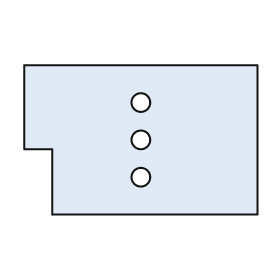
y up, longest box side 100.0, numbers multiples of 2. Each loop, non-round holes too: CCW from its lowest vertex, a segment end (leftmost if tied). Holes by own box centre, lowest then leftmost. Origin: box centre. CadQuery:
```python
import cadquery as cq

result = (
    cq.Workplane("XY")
    .moveTo(-38.0, -32.0)
    .lineTo(50.0, -32.0)
    .lineTo(50.0, 32.0)
    .lineTo(-50.0, 32.0)
    .lineTo(-50.0, -4.0)
    .lineTo(-38.0, -4.0)
    .close()
    .moveTo(0.0, -16.0)
    .circle(4.0)
    .moveTo(0.0, 0.0)
    .circle(4.0)
    .moveTo(0.0, 16.0)
    .circle(4.0)
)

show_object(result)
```